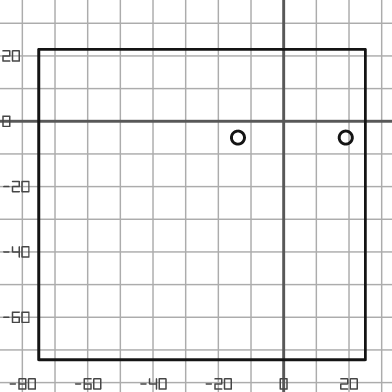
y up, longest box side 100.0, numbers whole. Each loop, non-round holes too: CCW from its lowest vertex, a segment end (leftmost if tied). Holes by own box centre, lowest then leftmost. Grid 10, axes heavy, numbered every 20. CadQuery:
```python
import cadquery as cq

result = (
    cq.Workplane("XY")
    .moveTo(-75.0, -73.0)
    .lineTo(25.0, -73.0)
    .lineTo(25.0, 22.0)
    .lineTo(-75.0, 22.0)
    .close()
    .moveTo(-14.0, -5.0)
    .circle(2.0)
    .moveTo(19.0, -5.0)
    .circle(2.0)
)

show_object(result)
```